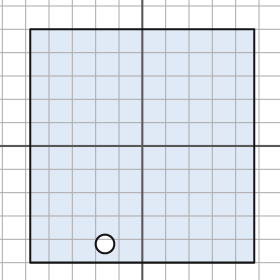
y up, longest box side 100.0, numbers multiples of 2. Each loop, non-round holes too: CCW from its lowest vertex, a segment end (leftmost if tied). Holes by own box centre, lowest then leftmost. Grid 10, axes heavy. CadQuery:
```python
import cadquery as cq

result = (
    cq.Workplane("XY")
    .moveTo(-48.0, -50.0)
    .lineTo(48.0, -50.0)
    .lineTo(48.0, 50.0)
    .lineTo(-48.0, 50.0)
    .close()
    .moveTo(-16.0, -42.0)
    .circle(4.0)
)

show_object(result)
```